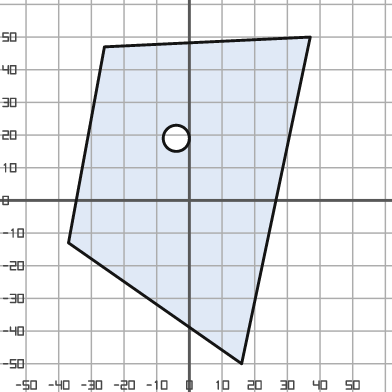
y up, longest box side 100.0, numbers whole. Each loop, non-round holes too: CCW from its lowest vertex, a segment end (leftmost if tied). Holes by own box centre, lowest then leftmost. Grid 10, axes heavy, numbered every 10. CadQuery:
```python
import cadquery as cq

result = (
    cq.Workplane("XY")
    .moveTo(16.0, -50.0)
    .lineTo(37.0, 50.0)
    .lineTo(-26.0, 47.0)
    .lineTo(-37.0, -13.0)
    .close()
    .moveTo(-4.0, 19.0)
    .circle(4.0)
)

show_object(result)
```